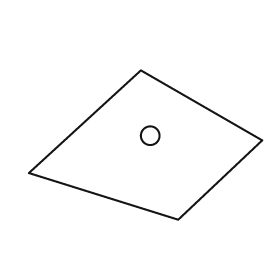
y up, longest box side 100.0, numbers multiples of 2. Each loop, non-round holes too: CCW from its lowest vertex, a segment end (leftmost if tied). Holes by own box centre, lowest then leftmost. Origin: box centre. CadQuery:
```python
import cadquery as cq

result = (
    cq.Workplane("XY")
    .moveTo(14.0, -32.0)
    .lineTo(50.0, 2.0)
    .lineTo(-2.0, 32.0)
    .lineTo(-50.0, -12.0)
    .close()
    .moveTo(2.0, 4.0)
    .circle(4.0)
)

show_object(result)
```